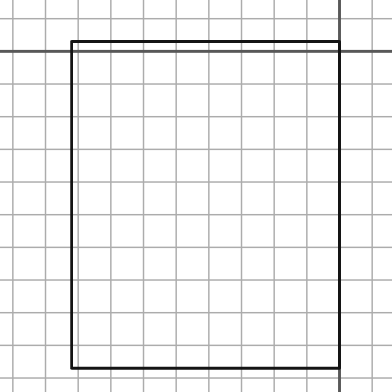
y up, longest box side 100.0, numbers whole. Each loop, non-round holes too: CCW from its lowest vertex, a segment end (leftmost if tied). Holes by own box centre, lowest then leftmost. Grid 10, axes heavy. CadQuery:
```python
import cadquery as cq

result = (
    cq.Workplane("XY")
    .moveTo(-82.0, -97.0)
    .lineTo(0.0, -97.0)
    .lineTo(0.0, 3.0)
    .lineTo(-82.0, 3.0)
    .close()
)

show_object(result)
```